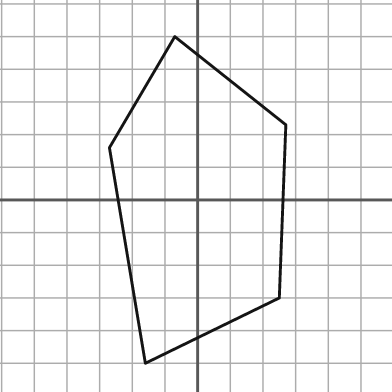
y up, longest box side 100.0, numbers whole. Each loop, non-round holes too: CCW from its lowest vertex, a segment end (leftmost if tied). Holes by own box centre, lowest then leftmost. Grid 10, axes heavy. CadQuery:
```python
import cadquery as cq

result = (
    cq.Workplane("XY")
    .moveTo(-16.0, -50.0)
    .lineTo(25.0, -30.0)
    .lineTo(27.0, 23.0)
    .lineTo(-7.0, 50.0)
    .lineTo(-27.0, 16.0)
    .close()
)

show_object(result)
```